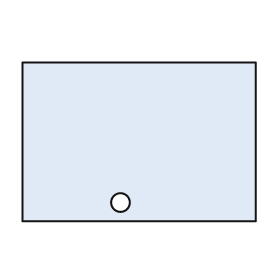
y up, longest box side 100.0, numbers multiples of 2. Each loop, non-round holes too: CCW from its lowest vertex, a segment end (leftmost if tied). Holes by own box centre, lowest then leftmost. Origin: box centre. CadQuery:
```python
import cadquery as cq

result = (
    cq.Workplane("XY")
    .moveTo(-50.0, -34.0)
    .lineTo(50.0, -34.0)
    .lineTo(50.0, 34.0)
    .lineTo(-50.0, 34.0)
    .close()
    .moveTo(-8.0, -26.0)
    .circle(4.0)
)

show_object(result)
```